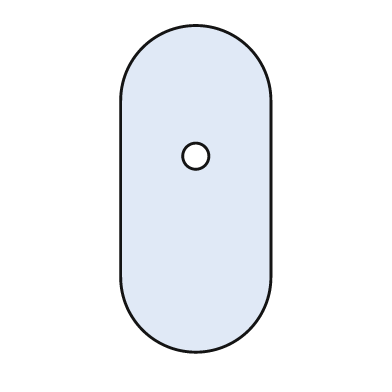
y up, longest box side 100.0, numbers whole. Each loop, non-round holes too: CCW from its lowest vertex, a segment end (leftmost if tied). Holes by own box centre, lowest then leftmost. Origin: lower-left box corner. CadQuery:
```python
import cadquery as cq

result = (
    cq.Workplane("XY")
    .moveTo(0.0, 23.0)
    .threePointArc((23.0, 0.0), (46.0, 23.0))
    .lineTo(46.0, 77.0)
    .threePointArc((23.0, 100.0), (0.0, 77.0))
    .close()
    .moveTo(23.0, 60.0)
    .circle(4.0)
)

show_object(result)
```